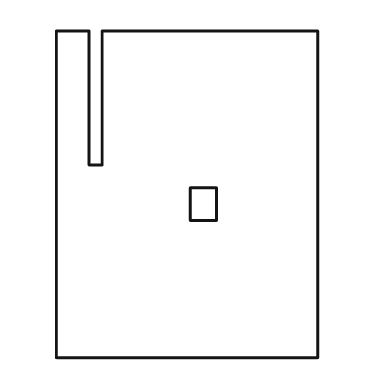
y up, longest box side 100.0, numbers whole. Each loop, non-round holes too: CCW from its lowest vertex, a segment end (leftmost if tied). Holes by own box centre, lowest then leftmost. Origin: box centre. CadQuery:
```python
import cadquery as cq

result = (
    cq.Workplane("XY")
    .moveTo(-40.0, -50.0)
    .lineTo(40.0, -50.0)
    .lineTo(40.0, 50.0)
    .lineTo(-26.0, 50.0)
    .lineTo(-26.0, 9.0)
    .lineTo(-30.0, 9.0)
    .lineTo(-30.0, 50.0)
    .lineTo(-40.0, 50.0)
    .close()
    .moveTo(1.0, -8.0)
    .lineTo(9.0, -8.0)
    .lineTo(9.0, 2.0)
    .lineTo(1.0, 2.0)
    .close()
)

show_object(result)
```